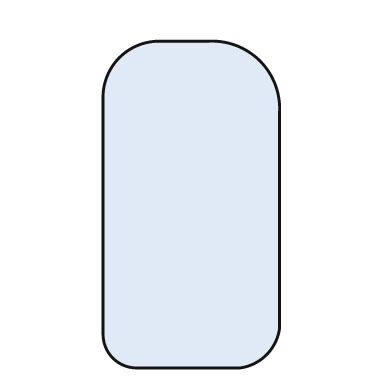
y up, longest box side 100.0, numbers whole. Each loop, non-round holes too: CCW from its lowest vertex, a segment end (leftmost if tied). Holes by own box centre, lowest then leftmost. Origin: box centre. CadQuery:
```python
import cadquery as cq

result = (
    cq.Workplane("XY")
    .moveTo(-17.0, -50.0)
    .lineTo(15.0, -50.0)
    .threePointArc((23.0, -46.0), (27.0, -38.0))
    .lineTo(27.0, 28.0)
    .threePointArc((21.0, 44.0), (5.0, 50.0))
    .lineTo(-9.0, 50.0)
    .threePointArc((-22.0, 45.0), (-27.0, 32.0))
    .lineTo(-27.0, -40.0)
    .threePointArc((-24.0, -47.0), (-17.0, -50.0))
    .close()
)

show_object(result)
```